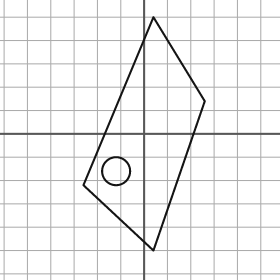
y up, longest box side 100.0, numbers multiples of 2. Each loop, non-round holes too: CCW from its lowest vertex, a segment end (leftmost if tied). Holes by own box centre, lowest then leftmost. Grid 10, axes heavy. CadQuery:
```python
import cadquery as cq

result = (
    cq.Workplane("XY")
    .moveTo(4.0, -50.0)
    .lineTo(26.0, 14.0)
    .lineTo(4.0, 50.0)
    .lineTo(-26.0, -22.0)
    .close()
    .moveTo(-12.0, -16.0)
    .circle(6.0)
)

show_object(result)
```